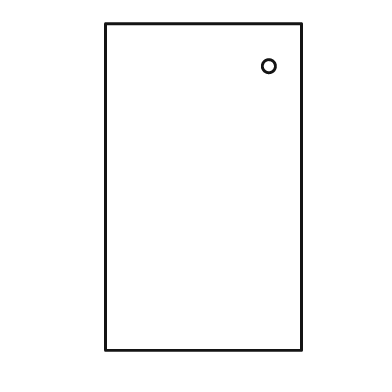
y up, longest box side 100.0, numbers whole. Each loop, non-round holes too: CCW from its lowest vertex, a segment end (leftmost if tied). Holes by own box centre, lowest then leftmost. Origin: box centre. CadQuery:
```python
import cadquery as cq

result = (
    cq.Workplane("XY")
    .moveTo(-30.0, -50.0)
    .lineTo(30.0, -50.0)
    .lineTo(30.0, 50.0)
    .lineTo(-30.0, 50.0)
    .close()
    .moveTo(20.0, 37.0)
    .circle(2.0)
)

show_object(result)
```